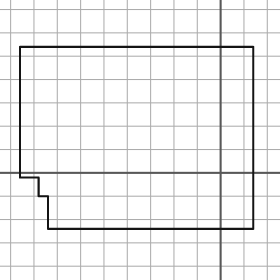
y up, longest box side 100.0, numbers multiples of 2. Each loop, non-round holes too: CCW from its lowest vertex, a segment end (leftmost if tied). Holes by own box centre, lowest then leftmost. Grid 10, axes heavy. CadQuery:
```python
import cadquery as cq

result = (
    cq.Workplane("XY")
    .moveTo(-74.0, -24.0)
    .lineTo(14.0, -24.0)
    .lineTo(14.0, 54.0)
    .lineTo(-86.0, 54.0)
    .lineTo(-86.0, -2.0)
    .lineTo(-78.0, -2.0)
    .lineTo(-78.0, -10.0)
    .lineTo(-74.0, -10.0)
    .close()
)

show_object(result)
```